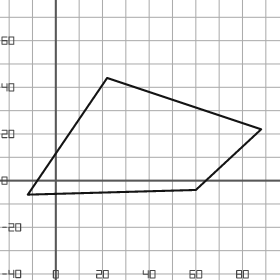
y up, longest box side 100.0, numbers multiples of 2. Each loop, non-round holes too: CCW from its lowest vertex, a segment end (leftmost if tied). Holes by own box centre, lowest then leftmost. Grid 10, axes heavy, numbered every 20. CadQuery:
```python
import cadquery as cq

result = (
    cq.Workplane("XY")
    .moveTo(-12.0, -6.0)
    .lineTo(60.0, -4.0)
    .lineTo(88.0, 22.0)
    .lineTo(22.0, 44.0)
    .close()
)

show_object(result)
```